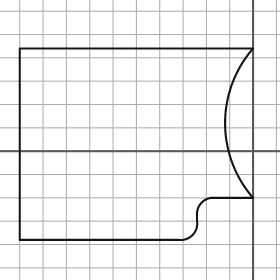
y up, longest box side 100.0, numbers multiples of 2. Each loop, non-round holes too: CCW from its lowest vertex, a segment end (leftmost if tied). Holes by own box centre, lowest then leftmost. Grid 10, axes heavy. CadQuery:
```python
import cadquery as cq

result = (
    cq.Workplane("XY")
    .moveTo(-100.0, -38.0)
    .lineTo(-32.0, -38.0)
    .threePointArc((-26.0, -36.0), (-24.0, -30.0))
    .lineTo(-24.0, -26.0)
    .threePointArc((-22.0, -22.0), (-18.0, -20.0))
    .lineTo(0.0, -20.0)
    .threePointArc((-12.0, 12.0), (0.0, 44.0))
    .lineTo(-100.0, 44.0)
    .close()
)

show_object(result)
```